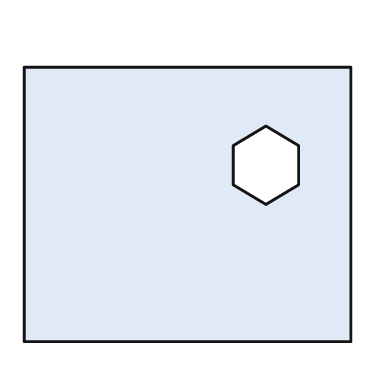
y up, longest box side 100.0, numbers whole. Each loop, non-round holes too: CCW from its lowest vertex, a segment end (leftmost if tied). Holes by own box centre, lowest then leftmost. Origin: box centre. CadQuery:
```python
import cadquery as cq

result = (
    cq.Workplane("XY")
    .moveTo(-50.0, -42.0)
    .lineTo(50.0, -42.0)
    .lineTo(50.0, 42.0)
    .lineTo(-50.0, 42.0)
    .close()
    .moveTo(24.0, 0.0)
    .lineTo(34.0, 6.0)
    .lineTo(34.0, 18.0)
    .lineTo(24.0, 24.0)
    .lineTo(14.0, 18.0)
    .lineTo(14.0, 6.0)
    .close()
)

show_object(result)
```